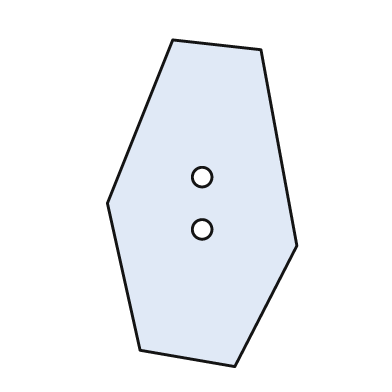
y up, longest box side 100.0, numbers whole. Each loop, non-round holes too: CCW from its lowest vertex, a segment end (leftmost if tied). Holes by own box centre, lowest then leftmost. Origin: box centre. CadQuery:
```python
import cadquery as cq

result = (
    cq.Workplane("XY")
    .moveTo(10.0, -50.0)
    .lineTo(29.0, -13.0)
    .lineTo(18.0, 47.0)
    .lineTo(-9.0, 50.0)
    .lineTo(-29.0, 0.0)
    .lineTo(-19.0, -45.0)
    .close()
    .moveTo(0.0, -8.0)
    .circle(3.0)
    .moveTo(0.0, 8.0)
    .circle(3.0)
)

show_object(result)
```